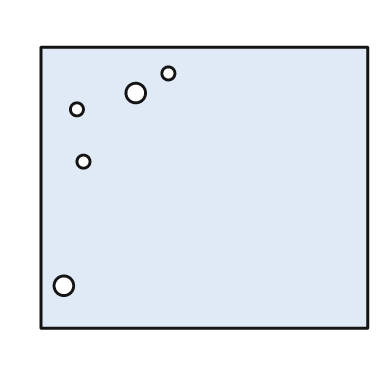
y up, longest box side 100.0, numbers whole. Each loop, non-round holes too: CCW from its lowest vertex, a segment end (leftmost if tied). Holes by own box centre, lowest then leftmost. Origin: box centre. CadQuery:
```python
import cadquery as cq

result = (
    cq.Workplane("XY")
    .moveTo(-50.0, -43.0)
    .lineTo(50.0, -43.0)
    .lineTo(50.0, 43.0)
    .lineTo(-50.0, 43.0)
    .close()
    .moveTo(-43.0, -30.0)
    .circle(3.0)
    .moveTo(-37.0, 8.0)
    .circle(2.0)
    .moveTo(-39.0, 24.0)
    .circle(2.0)
    .moveTo(-21.0, 29.0)
    .circle(3.0)
    .moveTo(-11.0, 35.0)
    .circle(2.0)
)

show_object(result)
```